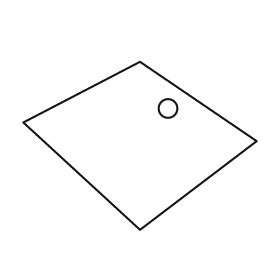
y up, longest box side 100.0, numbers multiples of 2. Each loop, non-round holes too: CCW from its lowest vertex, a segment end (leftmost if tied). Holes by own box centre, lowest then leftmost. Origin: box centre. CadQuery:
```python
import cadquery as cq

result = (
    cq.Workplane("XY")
    .moveTo(0.0, -36.0)
    .lineTo(50.0, 2.0)
    .lineTo(0.0, 36.0)
    .lineTo(-50.0, 10.0)
    .close()
    .moveTo(12.0, 16.0)
    .circle(4.0)
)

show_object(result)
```